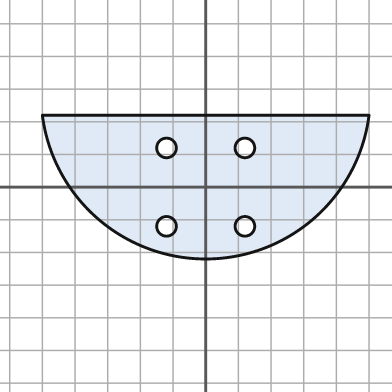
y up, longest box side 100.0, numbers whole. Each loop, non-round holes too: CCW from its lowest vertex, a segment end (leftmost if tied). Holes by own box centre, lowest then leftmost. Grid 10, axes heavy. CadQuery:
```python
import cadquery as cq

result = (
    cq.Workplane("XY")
    .moveTo(-50.0, 22.0)
    .threePointArc((0.0, -22.0), (50.0, 22.0))
    .close()
    .moveTo(-12.0, -12.0)
    .circle(3.0)
    .moveTo(12.0, -12.0)
    .circle(3.0)
    .moveTo(-12.0, 12.0)
    .circle(3.0)
    .moveTo(12.0, 12.0)
    .circle(3.0)
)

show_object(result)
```